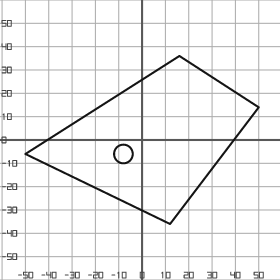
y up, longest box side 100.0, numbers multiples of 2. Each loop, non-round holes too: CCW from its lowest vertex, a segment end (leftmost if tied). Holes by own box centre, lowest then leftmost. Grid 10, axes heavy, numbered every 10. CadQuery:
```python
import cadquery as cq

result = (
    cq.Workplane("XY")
    .moveTo(12.0, -36.0)
    .lineTo(50.0, 14.0)
    .lineTo(16.0, 36.0)
    .lineTo(-50.0, -6.0)
    .close()
    .moveTo(-8.0, -6.0)
    .circle(4.0)
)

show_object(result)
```